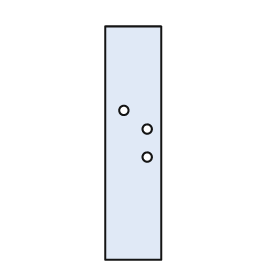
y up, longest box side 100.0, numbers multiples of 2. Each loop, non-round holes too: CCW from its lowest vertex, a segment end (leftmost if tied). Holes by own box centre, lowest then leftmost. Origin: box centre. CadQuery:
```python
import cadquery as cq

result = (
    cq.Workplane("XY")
    .moveTo(-12.0, -50.0)
    .lineTo(12.0, -50.0)
    .lineTo(12.0, 50.0)
    .lineTo(-12.0, 50.0)
    .close()
    .moveTo(6.0, -6.0)
    .circle(2.0)
    .moveTo(6.0, 6.0)
    .circle(2.0)
    .moveTo(-4.0, 14.0)
    .circle(2.0)
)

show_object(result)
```